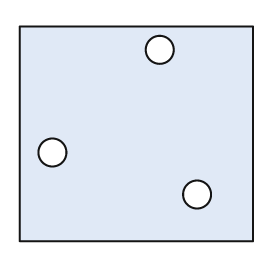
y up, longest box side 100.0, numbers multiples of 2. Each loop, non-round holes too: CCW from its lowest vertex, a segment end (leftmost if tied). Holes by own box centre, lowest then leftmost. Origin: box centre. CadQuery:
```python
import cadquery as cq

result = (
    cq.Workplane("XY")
    .moveTo(-50.0, -46.0)
    .lineTo(50.0, -46.0)
    .lineTo(50.0, 46.0)
    .lineTo(-50.0, 46.0)
    .close()
    .moveTo(26.0, -26.0)
    .circle(6.0)
    .moveTo(-36.0, -8.0)
    .circle(6.0)
    .moveTo(10.0, 36.0)
    .circle(6.0)
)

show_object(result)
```